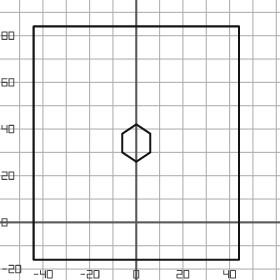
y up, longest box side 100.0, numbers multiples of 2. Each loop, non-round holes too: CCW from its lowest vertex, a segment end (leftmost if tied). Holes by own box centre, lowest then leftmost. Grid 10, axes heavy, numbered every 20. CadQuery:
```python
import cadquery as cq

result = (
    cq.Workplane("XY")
    .moveTo(-44.0, -16.0)
    .lineTo(44.0, -16.0)
    .lineTo(44.0, 84.0)
    .lineTo(-44.0, 84.0)
    .close()
    .moveTo(0.0, 26.0)
    .lineTo(6.0, 30.0)
    .lineTo(6.0, 38.0)
    .lineTo(0.0, 42.0)
    .lineTo(-6.0, 38.0)
    .lineTo(-6.0, 30.0)
    .close()
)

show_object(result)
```